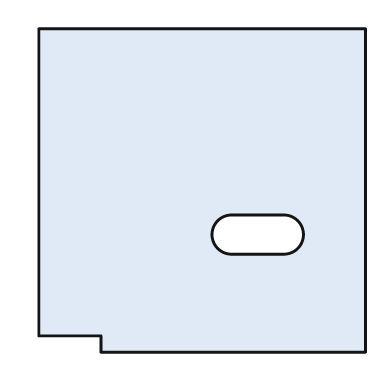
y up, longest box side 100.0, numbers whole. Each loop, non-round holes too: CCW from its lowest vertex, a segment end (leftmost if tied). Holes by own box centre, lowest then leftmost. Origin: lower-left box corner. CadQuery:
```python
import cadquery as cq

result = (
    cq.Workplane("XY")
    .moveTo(19.0, 0.0)
    .lineTo(100.0, 0.0)
    .lineTo(100.0, 99.0)
    .lineTo(0.0, 99.0)
    .lineTo(0.0, 5.0)
    .lineTo(19.0, 5.0)
    .close()
    .moveTo(59.0, 30.0)
    .lineTo(75.0, 30.0)
    .threePointArc((81.0, 36.0), (75.0, 42.0))
    .lineTo(59.0, 42.0)
    .threePointArc((53.0, 36.0), (59.0, 30.0))
    .close()
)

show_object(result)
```